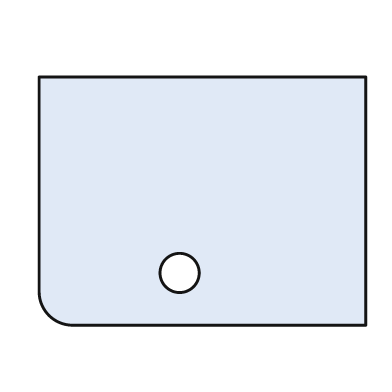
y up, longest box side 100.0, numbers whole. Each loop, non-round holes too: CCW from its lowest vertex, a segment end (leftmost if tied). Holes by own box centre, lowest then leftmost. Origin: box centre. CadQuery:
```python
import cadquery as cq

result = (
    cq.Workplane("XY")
    .moveTo(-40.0, -38.0)
    .lineTo(50.0, -38.0)
    .lineTo(50.0, 38.0)
    .lineTo(-50.0, 38.0)
    .lineTo(-50.0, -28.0)
    .threePointArc((-47.0, -35.0), (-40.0, -38.0))
    .close()
    .moveTo(-7.0, -22.0)
    .circle(6.0)
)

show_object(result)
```